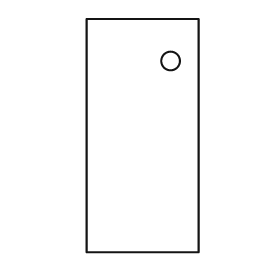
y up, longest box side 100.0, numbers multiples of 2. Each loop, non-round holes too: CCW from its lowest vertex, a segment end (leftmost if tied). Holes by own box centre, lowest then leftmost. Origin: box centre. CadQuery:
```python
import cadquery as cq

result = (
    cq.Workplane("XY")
    .moveTo(-24.0, -50.0)
    .lineTo(24.0, -50.0)
    .lineTo(24.0, 50.0)
    .lineTo(-24.0, 50.0)
    .close()
    .moveTo(12.0, 32.0)
    .circle(4.0)
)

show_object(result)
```